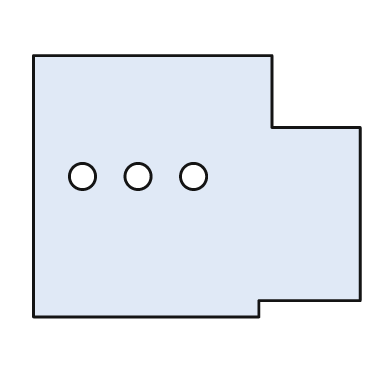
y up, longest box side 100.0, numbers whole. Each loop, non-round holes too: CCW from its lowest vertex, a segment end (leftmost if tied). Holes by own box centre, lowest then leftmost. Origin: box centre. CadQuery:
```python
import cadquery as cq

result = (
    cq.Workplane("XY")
    .moveTo(-50.0, -40.0)
    .lineTo(19.0, -40.0)
    .lineTo(19.0, -35.0)
    .lineTo(50.0, -35.0)
    .lineTo(50.0, 18.0)
    .lineTo(23.0, 18.0)
    .lineTo(23.0, 40.0)
    .lineTo(-50.0, 40.0)
    .close()
    .moveTo(-35.0, 3.0)
    .circle(4.0)
    .moveTo(-18.0, 3.0)
    .circle(4.0)
    .moveTo(-1.0, 3.0)
    .circle(4.0)
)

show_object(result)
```